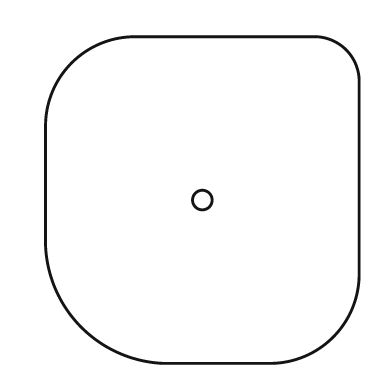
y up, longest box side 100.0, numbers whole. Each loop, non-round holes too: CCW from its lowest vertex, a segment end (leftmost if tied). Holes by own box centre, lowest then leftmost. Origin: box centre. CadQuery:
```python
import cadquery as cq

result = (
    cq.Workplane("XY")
    .moveTo(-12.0, -50.0)
    .lineTo(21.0, -50.0)
    .threePointArc((40.0, -42.0), (48.0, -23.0))
    .lineTo(48.0, 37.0)
    .threePointArc((44.0, 46.0), (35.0, 50.0))
    .lineTo(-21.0, 50.0)
    .threePointArc((-40.0, 42.0), (-48.0, 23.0))
    .lineTo(-48.0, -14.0)
    .threePointArc((-37.0, -39.0), (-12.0, -50.0))
    .close()
    .moveTo(0.0, 0.0)
    .circle(3.0)
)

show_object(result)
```